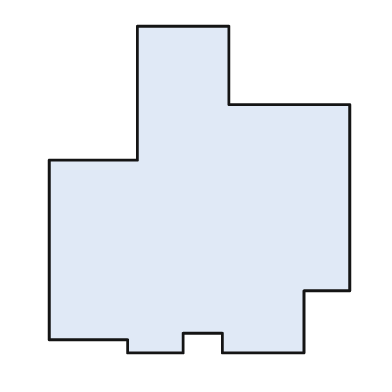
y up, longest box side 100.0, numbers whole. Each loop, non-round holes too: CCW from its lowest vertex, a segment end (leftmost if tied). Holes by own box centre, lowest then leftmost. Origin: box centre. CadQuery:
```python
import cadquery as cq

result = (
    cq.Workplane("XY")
    .moveTo(-22.0, -50.0)
    .lineTo(-5.0, -50.0)
    .lineTo(-5.0, -44.0)
    .lineTo(7.0, -44.0)
    .lineTo(7.0, -50.0)
    .lineTo(32.0, -50.0)
    .lineTo(32.0, -31.0)
    .lineTo(46.0, -31.0)
    .lineTo(46.0, 26.0)
    .lineTo(9.0, 26.0)
    .lineTo(9.0, 50.0)
    .lineTo(-19.0, 50.0)
    .lineTo(-19.0, 9.0)
    .lineTo(-46.0, 9.0)
    .lineTo(-46.0, -46.0)
    .lineTo(-22.0, -46.0)
    .close()
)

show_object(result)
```